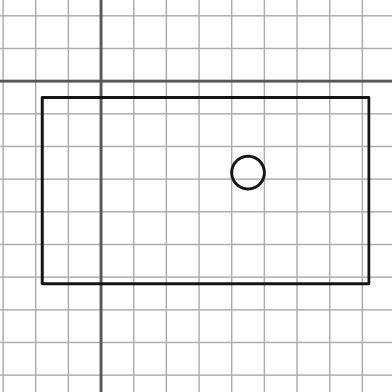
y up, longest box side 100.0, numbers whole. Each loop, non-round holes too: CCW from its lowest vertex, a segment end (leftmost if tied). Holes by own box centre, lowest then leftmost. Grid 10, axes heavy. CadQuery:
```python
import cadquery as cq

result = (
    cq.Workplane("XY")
    .moveTo(-18.0, -62.0)
    .lineTo(82.0, -62.0)
    .lineTo(82.0, -5.0)
    .lineTo(-18.0, -5.0)
    .close()
    .moveTo(45.0, -28.0)
    .circle(5.0)
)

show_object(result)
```